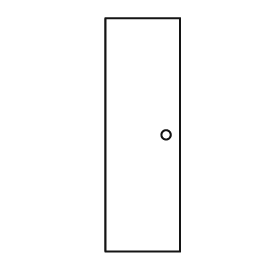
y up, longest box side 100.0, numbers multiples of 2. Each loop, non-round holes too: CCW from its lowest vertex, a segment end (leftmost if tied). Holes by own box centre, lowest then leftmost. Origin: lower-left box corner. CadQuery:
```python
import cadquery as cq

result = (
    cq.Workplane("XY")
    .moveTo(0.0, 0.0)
    .lineTo(32.0, 0.0)
    .lineTo(32.0, 100.0)
    .lineTo(0.0, 100.0)
    .close()
    .moveTo(26.0, 50.0)
    .circle(2.0)
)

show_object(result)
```